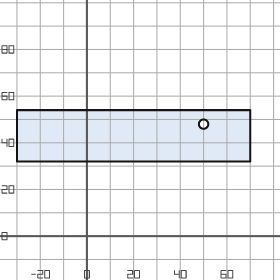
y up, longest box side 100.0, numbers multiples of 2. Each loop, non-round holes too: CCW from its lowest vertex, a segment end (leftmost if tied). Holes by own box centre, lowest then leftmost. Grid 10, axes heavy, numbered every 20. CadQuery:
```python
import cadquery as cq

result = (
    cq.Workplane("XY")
    .moveTo(-30.0, 32.0)
    .lineTo(70.0, 32.0)
    .lineTo(70.0, 54.0)
    .lineTo(-30.0, 54.0)
    .close()
    .moveTo(50.0, 48.0)
    .circle(2.0)
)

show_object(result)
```